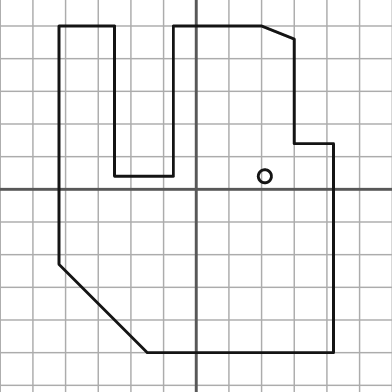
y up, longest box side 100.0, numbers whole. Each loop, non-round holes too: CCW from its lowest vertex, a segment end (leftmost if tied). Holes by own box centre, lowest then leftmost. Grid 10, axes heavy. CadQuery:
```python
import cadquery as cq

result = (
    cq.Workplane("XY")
    .moveTo(-15.0, -50.0)
    .lineTo(42.0, -50.0)
    .lineTo(42.0, 14.0)
    .lineTo(30.0, 14.0)
    .lineTo(30.0, 46.0)
    .lineTo(20.0, 50.0)
    .lineTo(-7.0, 50.0)
    .lineTo(-7.0, 4.0)
    .lineTo(-25.0, 4.0)
    .lineTo(-25.0, 50.0)
    .lineTo(-42.0, 50.0)
    .lineTo(-42.0, -23.0)
    .close()
    .moveTo(21.0, 4.0)
    .circle(2.0)
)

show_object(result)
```